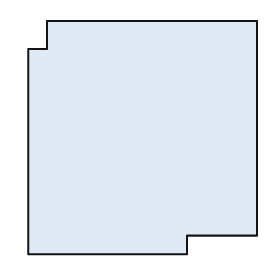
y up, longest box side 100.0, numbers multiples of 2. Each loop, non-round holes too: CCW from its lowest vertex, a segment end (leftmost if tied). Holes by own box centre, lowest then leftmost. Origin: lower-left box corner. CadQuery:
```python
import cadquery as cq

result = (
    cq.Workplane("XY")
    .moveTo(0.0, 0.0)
    .lineTo(68.0, 0.0)
    .lineTo(68.0, 8.0)
    .lineTo(98.0, 8.0)
    .lineTo(98.0, 100.0)
    .lineTo(8.0, 100.0)
    .lineTo(8.0, 88.0)
    .lineTo(0.0, 88.0)
    .close()
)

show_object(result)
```